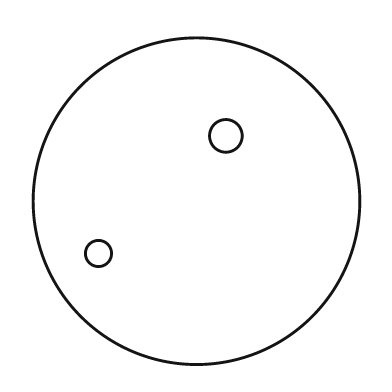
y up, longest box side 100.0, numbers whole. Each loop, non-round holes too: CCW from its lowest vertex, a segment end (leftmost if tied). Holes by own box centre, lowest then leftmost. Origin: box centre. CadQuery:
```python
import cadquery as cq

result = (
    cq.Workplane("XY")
    .moveTo(0.0, 0.0)
    .circle(50.0)
    .moveTo(-30.0, -16.0)
    .circle(4.0)
    .moveTo(9.0, 20.0)
    .circle(5.0)
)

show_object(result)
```